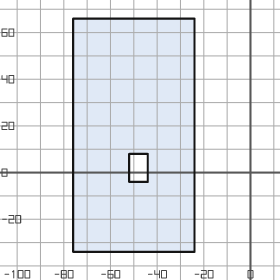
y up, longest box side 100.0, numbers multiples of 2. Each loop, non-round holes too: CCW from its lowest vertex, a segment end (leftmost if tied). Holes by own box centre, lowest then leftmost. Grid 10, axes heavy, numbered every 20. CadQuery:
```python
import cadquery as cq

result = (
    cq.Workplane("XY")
    .moveTo(-76.0, -34.0)
    .lineTo(-24.0, -34.0)
    .lineTo(-24.0, 66.0)
    .lineTo(-76.0, 66.0)
    .close()
    .moveTo(-52.0, -4.0)
    .lineTo(-44.0, -4.0)
    .lineTo(-44.0, 8.0)
    .lineTo(-52.0, 8.0)
    .close()
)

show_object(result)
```